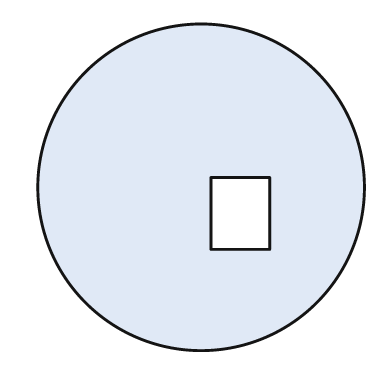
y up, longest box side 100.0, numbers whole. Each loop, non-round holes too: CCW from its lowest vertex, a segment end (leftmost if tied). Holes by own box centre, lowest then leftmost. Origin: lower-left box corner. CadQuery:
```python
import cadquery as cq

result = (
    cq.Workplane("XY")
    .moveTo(50.0, 50.0)
    .circle(50.0)
    .moveTo(53.0, 31.0)
    .lineTo(71.0, 31.0)
    .lineTo(71.0, 53.0)
    .lineTo(53.0, 53.0)
    .close()
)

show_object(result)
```